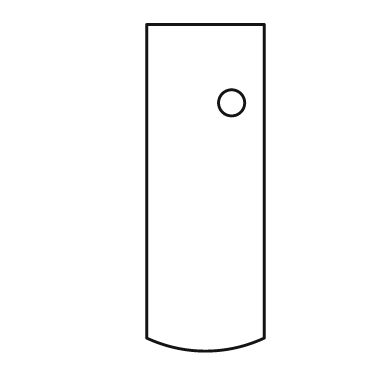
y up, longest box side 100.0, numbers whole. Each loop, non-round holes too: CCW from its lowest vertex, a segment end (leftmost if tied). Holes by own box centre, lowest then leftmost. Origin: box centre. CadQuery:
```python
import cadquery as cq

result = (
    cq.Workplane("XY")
    .moveTo(-18.0, -46.0)
    .threePointArc((0.0, -50.0), (18.0, -46.0))
    .lineTo(18.0, 50.0)
    .lineTo(-18.0, 50.0)
    .close()
    .moveTo(8.0, 26.0)
    .circle(4.0)
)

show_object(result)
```